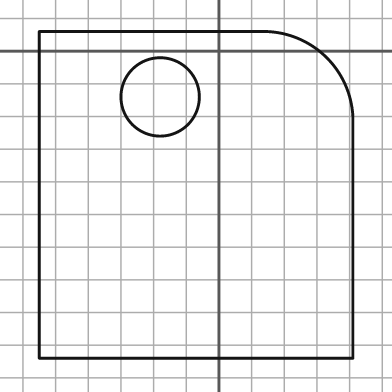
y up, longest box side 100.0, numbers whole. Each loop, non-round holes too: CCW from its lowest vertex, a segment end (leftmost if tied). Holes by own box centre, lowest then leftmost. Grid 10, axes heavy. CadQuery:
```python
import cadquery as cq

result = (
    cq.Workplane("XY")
    .moveTo(-55.0, -94.0)
    .lineTo(41.0, -94.0)
    .lineTo(41.0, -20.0)
    .threePointArc((33.0, -2.0), (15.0, 6.0))
    .lineTo(-55.0, 6.0)
    .close()
    .moveTo(-18.0, -14.0)
    .circle(12.0)
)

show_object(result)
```